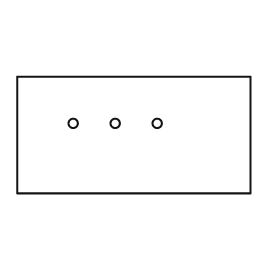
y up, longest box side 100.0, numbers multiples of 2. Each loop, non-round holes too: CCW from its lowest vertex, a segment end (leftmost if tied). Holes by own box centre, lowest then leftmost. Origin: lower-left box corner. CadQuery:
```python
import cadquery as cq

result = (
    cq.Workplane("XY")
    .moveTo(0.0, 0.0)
    .lineTo(100.0, 0.0)
    .lineTo(100.0, 50.0)
    .lineTo(0.0, 50.0)
    .close()
    .moveTo(24.0, 30.0)
    .circle(2.0)
    .moveTo(42.0, 30.0)
    .circle(2.0)
    .moveTo(60.0, 30.0)
    .circle(2.0)
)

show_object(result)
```